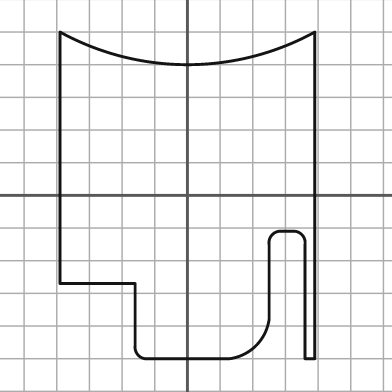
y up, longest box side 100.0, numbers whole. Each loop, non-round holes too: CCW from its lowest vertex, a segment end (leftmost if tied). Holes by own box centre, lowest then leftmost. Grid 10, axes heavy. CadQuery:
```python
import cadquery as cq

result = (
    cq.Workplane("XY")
    .moveTo(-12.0, -50.0)
    .lineTo(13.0, -50.0)
    .threePointArc((21.0, -46.0), (25.0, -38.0))
    .lineTo(25.0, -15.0)
    .threePointArc((26.0, -12.0), (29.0, -11.0))
    .lineTo(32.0, -11.0)
    .threePointArc((35.0, -12.0), (36.0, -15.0))
    .lineTo(36.0, -50.0)
    .lineTo(39.0, -50.0)
    .lineTo(39.0, 50.0)
    .threePointArc((0.0, 40.0), (-39.0, 50.0))
    .lineTo(-39.0, -27.0)
    .lineTo(-16.0, -27.0)
    .lineTo(-16.0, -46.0)
    .threePointArc((-15.0, -49.0), (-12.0, -50.0))
    .close()
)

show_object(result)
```